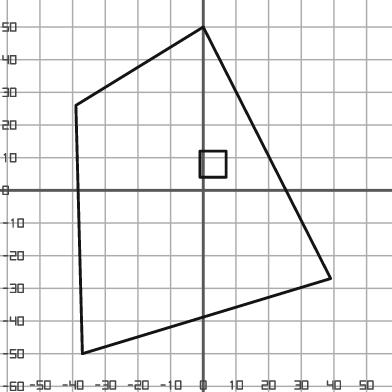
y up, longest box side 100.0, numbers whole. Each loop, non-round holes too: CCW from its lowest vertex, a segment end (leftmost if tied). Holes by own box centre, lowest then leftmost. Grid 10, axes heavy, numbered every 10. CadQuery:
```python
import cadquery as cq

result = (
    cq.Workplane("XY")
    .moveTo(-37.0, -50.0)
    .lineTo(39.0, -27.0)
    .lineTo(0.0, 50.0)
    .lineTo(-39.0, 26.0)
    .close()
    .moveTo(-1.0, 4.0)
    .lineTo(7.0, 4.0)
    .lineTo(7.0, 12.0)
    .lineTo(-1.0, 12.0)
    .close()
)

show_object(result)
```